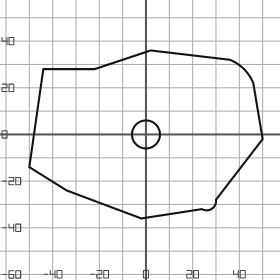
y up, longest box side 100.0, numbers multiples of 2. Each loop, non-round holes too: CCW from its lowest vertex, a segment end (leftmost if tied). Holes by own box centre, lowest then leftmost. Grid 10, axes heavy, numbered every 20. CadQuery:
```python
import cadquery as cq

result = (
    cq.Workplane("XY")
    .moveTo(-2.0, -36.0)
    .lineTo(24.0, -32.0)
    .threePointArc((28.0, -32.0), (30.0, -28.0))
    .lineTo(50.0, -2.0)
    .lineTo(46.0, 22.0)
    .threePointArc((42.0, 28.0), (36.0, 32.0))
    .lineTo(2.0, 36.0)
    .lineTo(-22.0, 28.0)
    .lineTo(-44.0, 28.0)
    .lineTo(-50.0, -14.0)
    .lineTo(-34.0, -24.0)
    .close()
    .moveTo(0.0, 0.0)
    .circle(6.0)
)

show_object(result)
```